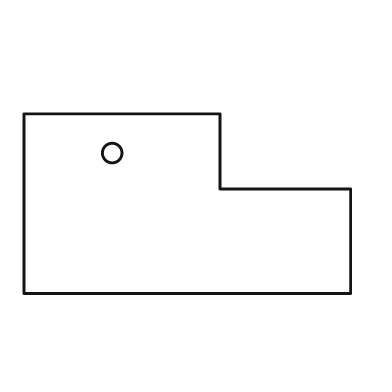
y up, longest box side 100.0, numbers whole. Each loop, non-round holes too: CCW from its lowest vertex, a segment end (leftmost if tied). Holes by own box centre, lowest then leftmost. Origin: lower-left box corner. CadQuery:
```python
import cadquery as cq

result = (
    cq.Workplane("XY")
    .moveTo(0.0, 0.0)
    .lineTo(100.0, 0.0)
    .lineTo(100.0, 32.0)
    .lineTo(60.0, 32.0)
    .lineTo(60.0, 55.0)
    .lineTo(0.0, 55.0)
    .close()
    .moveTo(27.0, 43.0)
    .circle(3.0)
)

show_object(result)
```